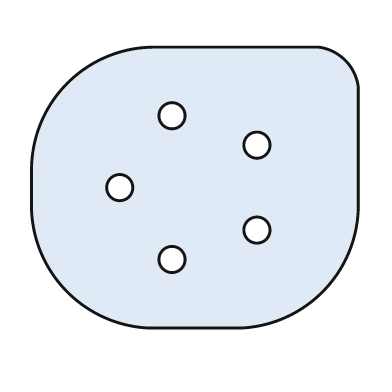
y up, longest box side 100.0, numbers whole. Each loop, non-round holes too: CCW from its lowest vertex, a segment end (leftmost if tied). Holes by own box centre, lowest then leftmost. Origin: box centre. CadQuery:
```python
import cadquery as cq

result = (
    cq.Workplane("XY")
    .moveTo(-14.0, -43.0)
    .lineTo(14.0, -43.0)
    .threePointArc((39.0, -32.0), (50.0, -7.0))
    .lineTo(50.0, 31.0)
    .threePointArc((46.0, 39.0), (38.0, 43.0))
    .lineTo(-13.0, 43.0)
    .threePointArc((-39.0, 32.0), (-50.0, 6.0))
    .lineTo(-50.0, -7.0)
    .threePointArc((-39.0, -32.0), (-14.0, -43.0))
    .close()
    .moveTo(-7.0, -22.0)
    .circle(4.0)
    .moveTo(19.0, -13.0)
    .circle(4.0)
    .moveTo(-23.0, 0.0)
    .circle(4.0)
    .moveTo(19.0, 13.0)
    .circle(4.0)
    .moveTo(-7.0, 22.0)
    .circle(4.0)
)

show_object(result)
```